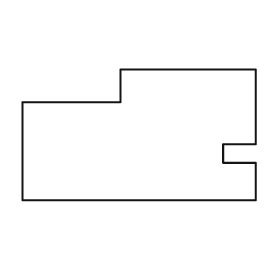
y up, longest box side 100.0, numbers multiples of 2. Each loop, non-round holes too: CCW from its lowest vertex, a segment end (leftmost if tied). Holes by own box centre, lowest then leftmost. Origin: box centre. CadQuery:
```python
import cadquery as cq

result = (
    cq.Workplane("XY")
    .moveTo(-50.0, -28.0)
    .lineTo(50.0, -28.0)
    .lineTo(50.0, -12.0)
    .lineTo(36.0, -12.0)
    .lineTo(36.0, -4.0)
    .lineTo(50.0, -4.0)
    .lineTo(50.0, 28.0)
    .lineTo(-8.0, 28.0)
    .lineTo(-8.0, 14.0)
    .lineTo(-50.0, 14.0)
    .close()
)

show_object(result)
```